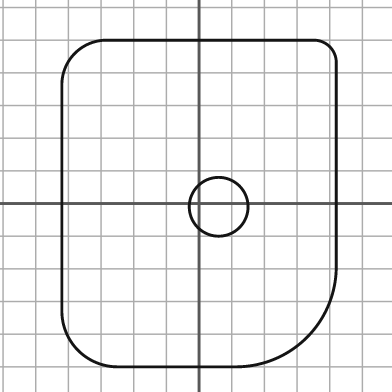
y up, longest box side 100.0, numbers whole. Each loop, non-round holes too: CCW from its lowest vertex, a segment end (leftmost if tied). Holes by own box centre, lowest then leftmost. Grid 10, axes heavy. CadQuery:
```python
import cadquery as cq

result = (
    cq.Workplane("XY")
    .moveTo(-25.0, -50.0)
    .lineTo(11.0, -50.0)
    .threePointArc((33.0, -41.0), (42.0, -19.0))
    .lineTo(42.0, 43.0)
    .threePointArc((40.0, 48.0), (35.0, 50.0))
    .lineTo(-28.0, 50.0)
    .threePointArc((-38.0, 46.0), (-42.0, 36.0))
    .lineTo(-42.0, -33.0)
    .threePointArc((-37.0, -45.0), (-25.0, -50.0))
    .close()
    .moveTo(6.0, -1.0)
    .circle(9.0)
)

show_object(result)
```